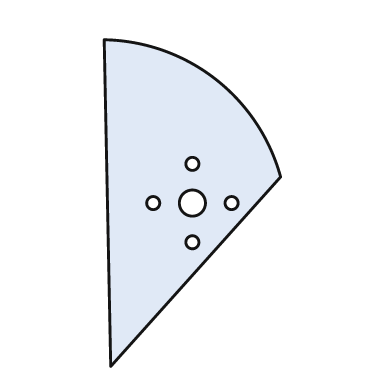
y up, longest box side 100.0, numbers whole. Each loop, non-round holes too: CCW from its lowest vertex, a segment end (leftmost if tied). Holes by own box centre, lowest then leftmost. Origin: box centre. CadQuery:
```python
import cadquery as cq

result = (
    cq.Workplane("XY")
    .moveTo(-25.0, -50.0)
    .lineTo(27.0, 8.0)
    .threePointArc((7.0, 38.0), (-27.0, 50.0))
    .close()
    .moveTo(0.0, -12.0)
    .circle(2.0)
    .moveTo(-12.0, 0.0)
    .circle(2.0)
    .moveTo(0.0, 0.0)
    .circle(4.0)
    .moveTo(12.0, 0.0)
    .circle(2.0)
    .moveTo(0.0, 12.0)
    .circle(2.0)
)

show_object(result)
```